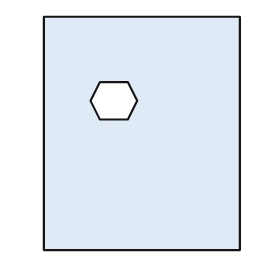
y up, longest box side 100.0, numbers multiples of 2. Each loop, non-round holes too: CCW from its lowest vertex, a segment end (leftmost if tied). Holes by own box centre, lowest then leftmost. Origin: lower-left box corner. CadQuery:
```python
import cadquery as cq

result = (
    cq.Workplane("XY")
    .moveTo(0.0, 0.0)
    .lineTo(84.0, 0.0)
    .lineTo(84.0, 100.0)
    .lineTo(0.0, 100.0)
    .close()
    .moveTo(24.0, 56.0)
    .lineTo(36.0, 56.0)
    .lineTo(40.0, 64.0)
    .lineTo(36.0, 72.0)
    .lineTo(24.0, 72.0)
    .lineTo(20.0, 64.0)
    .close()
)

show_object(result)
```